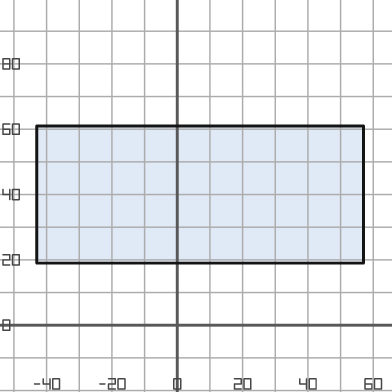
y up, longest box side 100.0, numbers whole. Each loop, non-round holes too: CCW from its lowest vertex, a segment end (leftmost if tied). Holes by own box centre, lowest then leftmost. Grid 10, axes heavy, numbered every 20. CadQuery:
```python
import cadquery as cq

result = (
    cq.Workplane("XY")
    .moveTo(-43.0, 19.0)
    .lineTo(57.0, 19.0)
    .lineTo(57.0, 61.0)
    .lineTo(-43.0, 61.0)
    .close()
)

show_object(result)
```